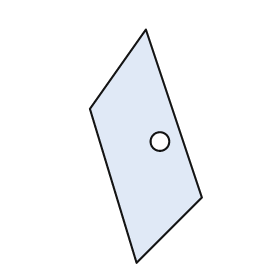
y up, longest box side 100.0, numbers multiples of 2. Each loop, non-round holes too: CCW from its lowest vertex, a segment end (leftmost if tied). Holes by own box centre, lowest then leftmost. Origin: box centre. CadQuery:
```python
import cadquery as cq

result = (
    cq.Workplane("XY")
    .moveTo(-4.0, -50.0)
    .lineTo(24.0, -22.0)
    .lineTo(0.0, 50.0)
    .lineTo(-24.0, 16.0)
    .close()
    .moveTo(6.0, 2.0)
    .circle(4.0)
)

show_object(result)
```